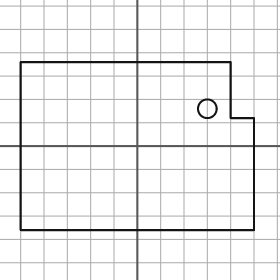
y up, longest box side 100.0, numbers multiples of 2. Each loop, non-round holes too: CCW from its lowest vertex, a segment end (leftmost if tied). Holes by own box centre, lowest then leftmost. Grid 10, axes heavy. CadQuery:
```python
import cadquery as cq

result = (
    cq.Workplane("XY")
    .moveTo(-50.0, -36.0)
    .lineTo(50.0, -36.0)
    .lineTo(50.0, 12.0)
    .lineTo(40.0, 12.0)
    .lineTo(40.0, 36.0)
    .lineTo(-50.0, 36.0)
    .close()
    .moveTo(30.0, 16.0)
    .circle(4.0)
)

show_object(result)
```